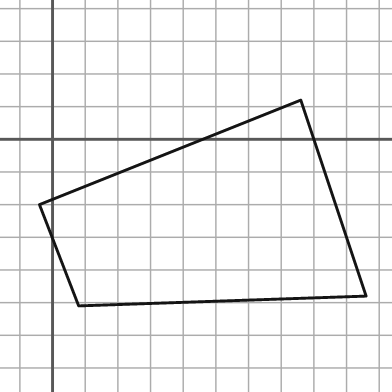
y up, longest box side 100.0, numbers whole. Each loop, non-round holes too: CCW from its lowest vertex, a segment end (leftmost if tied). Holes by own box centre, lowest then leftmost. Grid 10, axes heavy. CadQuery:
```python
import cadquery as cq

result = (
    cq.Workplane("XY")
    .moveTo(8.0, -51.0)
    .lineTo(96.0, -48.0)
    .lineTo(76.0, 12.0)
    .lineTo(-4.0, -20.0)
    .close()
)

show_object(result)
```